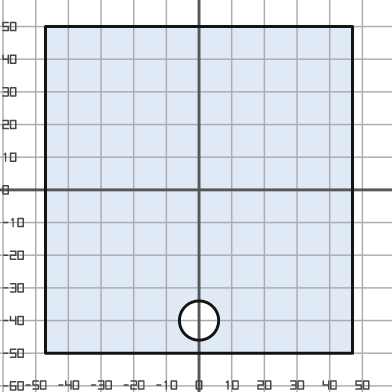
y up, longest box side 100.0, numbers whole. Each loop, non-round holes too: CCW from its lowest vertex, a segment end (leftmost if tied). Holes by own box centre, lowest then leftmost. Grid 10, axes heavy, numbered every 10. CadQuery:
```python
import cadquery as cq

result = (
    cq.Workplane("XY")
    .moveTo(-47.0, -50.0)
    .lineTo(47.0, -50.0)
    .lineTo(47.0, 50.0)
    .lineTo(-47.0, 50.0)
    .close()
    .moveTo(0.0, -40.0)
    .circle(6.0)
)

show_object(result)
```